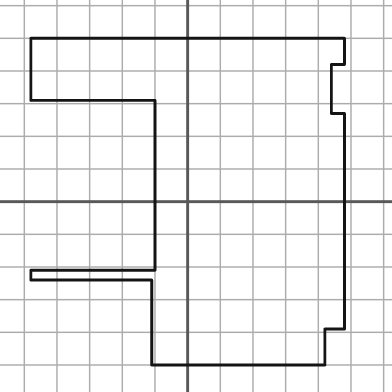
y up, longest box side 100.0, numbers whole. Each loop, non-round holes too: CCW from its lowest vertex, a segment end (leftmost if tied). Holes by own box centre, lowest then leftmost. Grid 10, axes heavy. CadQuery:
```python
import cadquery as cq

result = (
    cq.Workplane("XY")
    .moveTo(-11.0, -50.0)
    .lineTo(42.0, -50.0)
    .lineTo(42.0, -39.0)
    .lineTo(48.0, -39.0)
    .lineTo(48.0, 27.0)
    .lineTo(44.0, 27.0)
    .lineTo(44.0, 42.0)
    .lineTo(48.0, 42.0)
    .lineTo(48.0, 50.0)
    .lineTo(-48.0, 50.0)
    .lineTo(-48.0, 31.0)
    .lineTo(-10.0, 31.0)
    .lineTo(-10.0, -21.0)
    .lineTo(-48.0, -21.0)
    .lineTo(-48.0, -24.0)
    .lineTo(-11.0, -24.0)
    .close()
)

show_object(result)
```